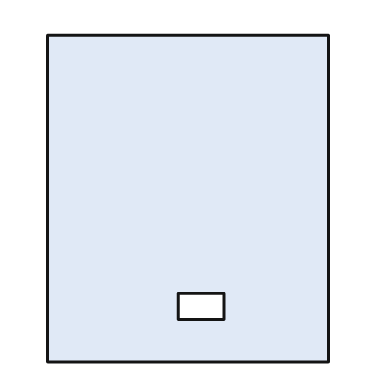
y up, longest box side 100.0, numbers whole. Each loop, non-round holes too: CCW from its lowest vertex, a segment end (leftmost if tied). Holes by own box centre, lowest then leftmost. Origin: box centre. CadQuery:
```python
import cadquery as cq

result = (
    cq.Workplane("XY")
    .moveTo(-43.0, -50.0)
    .lineTo(43.0, -50.0)
    .lineTo(43.0, 50.0)
    .lineTo(-43.0, 50.0)
    .close()
    .moveTo(-3.0, -37.0)
    .lineTo(11.0, -37.0)
    .lineTo(11.0, -29.0)
    .lineTo(-3.0, -29.0)
    .close()
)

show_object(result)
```